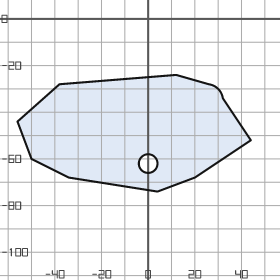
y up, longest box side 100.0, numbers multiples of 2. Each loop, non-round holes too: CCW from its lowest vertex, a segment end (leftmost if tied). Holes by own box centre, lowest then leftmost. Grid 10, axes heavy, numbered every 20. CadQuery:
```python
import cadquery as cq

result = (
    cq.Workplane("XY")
    .moveTo(4.0, -74.0)
    .lineTo(20.0, -68.0)
    .lineTo(44.0, -52.0)
    .lineTo(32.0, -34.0)
    .threePointArc((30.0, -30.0), (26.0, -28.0))
    .lineTo(12.0, -24.0)
    .lineTo(-38.0, -28.0)
    .lineTo(-56.0, -44.0)
    .lineTo(-50.0, -60.0)
    .lineTo(-34.0, -68.0)
    .close()
    .moveTo(0.0, -62.0)
    .circle(4.0)
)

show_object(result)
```